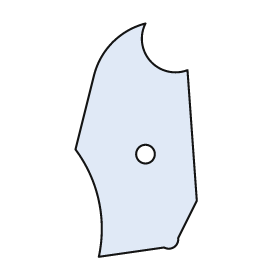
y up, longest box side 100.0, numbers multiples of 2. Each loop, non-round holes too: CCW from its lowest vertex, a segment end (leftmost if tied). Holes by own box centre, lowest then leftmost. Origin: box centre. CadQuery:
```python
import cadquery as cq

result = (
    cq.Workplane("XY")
    .moveTo(-16.0, -50.0)
    .lineTo(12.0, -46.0)
    .threePointArc((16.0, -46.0), (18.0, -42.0))
    .lineTo(26.0, -26.0)
    .lineTo(22.0, 30.0)
    .threePointArc((6.0, 34.0), (4.0, 50.0))
    .threePointArc((-10.0, 42.0), (-18.0, 28.0))
    .lineTo(-26.0, -4.0)
    .threePointArc((-16.0, -26.0), (-16.0, -50.0))
    .close()
    .moveTo(4.0, -6.0)
    .circle(4.0)
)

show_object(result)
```